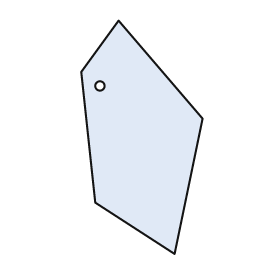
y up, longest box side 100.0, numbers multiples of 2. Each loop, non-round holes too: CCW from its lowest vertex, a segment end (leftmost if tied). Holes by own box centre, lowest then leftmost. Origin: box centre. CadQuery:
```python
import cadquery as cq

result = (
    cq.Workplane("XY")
    .moveTo(14.0, -50.0)
    .lineTo(26.0, 8.0)
    .lineTo(-10.0, 50.0)
    .lineTo(-26.0, 28.0)
    .lineTo(-20.0, -28.0)
    .close()
    .moveTo(-18.0, 22.0)
    .circle(2.0)
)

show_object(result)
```